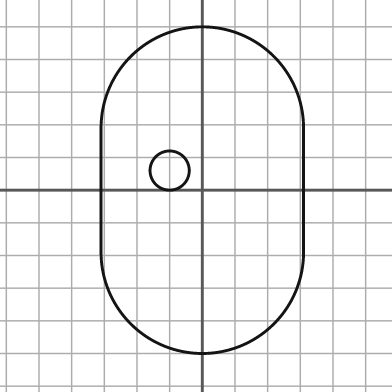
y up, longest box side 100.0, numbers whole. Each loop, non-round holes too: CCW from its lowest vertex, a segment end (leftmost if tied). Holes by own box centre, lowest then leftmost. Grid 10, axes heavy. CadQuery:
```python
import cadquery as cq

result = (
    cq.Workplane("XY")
    .moveTo(-31.0, -19.0)
    .threePointArc((0.0, -50.0), (31.0, -19.0))
    .lineTo(31.0, 19.0)
    .threePointArc((0.0, 50.0), (-31.0, 19.0))
    .close()
    .moveTo(-10.0, 6.0)
    .circle(6.0)
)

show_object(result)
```